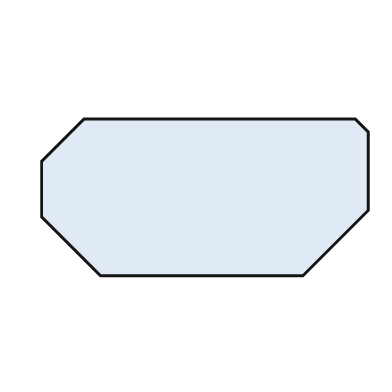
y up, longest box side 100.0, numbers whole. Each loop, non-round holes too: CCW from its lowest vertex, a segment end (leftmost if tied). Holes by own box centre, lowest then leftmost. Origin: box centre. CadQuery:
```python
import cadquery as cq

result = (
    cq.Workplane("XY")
    .moveTo(-32.0, -24.0)
    .lineTo(30.0, -24.0)
    .lineTo(50.0, -4.0)
    .lineTo(50.0, 20.0)
    .lineTo(46.0, 24.0)
    .lineTo(-37.0, 24.0)
    .lineTo(-50.0, 11.0)
    .lineTo(-50.0, -6.0)
    .close()
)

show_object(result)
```